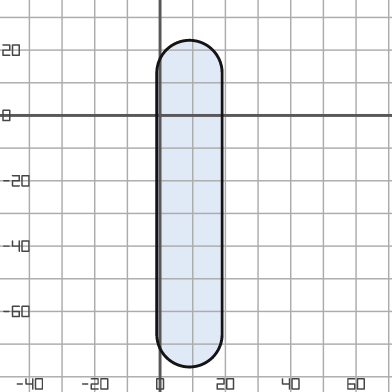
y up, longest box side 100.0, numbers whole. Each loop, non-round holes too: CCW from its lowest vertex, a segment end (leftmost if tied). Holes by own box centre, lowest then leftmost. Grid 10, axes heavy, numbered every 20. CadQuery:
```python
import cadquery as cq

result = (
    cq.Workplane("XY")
    .moveTo(-1.0, -67.0)
    .threePointArc((9.0, -77.0), (19.0, -67.0))
    .lineTo(19.0, 13.0)
    .threePointArc((9.0, 23.0), (-1.0, 13.0))
    .close()
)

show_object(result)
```